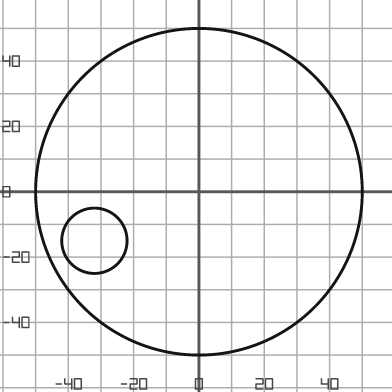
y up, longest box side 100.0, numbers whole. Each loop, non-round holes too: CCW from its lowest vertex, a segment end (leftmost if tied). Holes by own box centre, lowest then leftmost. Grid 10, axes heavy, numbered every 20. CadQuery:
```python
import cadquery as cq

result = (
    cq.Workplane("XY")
    .moveTo(0.0, 0.0)
    .circle(50.0)
    .moveTo(-32.0, -15.0)
    .circle(10.0)
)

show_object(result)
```